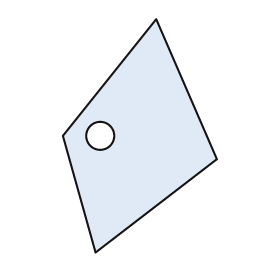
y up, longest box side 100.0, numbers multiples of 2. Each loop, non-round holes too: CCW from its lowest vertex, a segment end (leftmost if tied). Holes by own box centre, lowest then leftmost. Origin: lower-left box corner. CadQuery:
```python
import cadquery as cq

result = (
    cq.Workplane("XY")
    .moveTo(14.0, 0.0)
    .lineTo(66.0, 40.0)
    .lineTo(40.0, 100.0)
    .lineTo(0.0, 50.0)
    .close()
    .moveTo(16.0, 50.0)
    .circle(6.0)
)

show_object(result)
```